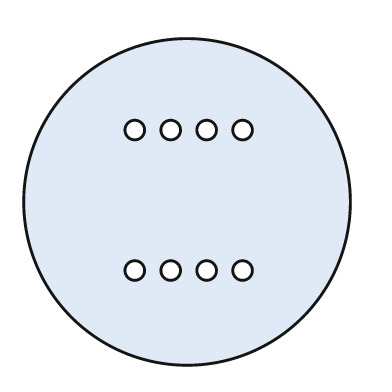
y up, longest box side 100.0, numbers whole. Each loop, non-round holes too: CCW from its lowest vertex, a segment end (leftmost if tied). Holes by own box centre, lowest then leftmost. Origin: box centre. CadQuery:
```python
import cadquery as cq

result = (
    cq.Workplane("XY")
    .moveTo(0.0, 0.0)
    .circle(50.0)
    .moveTo(-16.0, -21.0)
    .circle(3.0)
    .moveTo(-5.0, -21.0)
    .circle(3.0)
    .moveTo(6.0, -21.0)
    .circle(3.0)
    .moveTo(17.0, -21.0)
    .circle(3.0)
    .moveTo(-16.0, 22.0)
    .circle(3.0)
    .moveTo(-5.0, 22.0)
    .circle(3.0)
    .moveTo(6.0, 22.0)
    .circle(3.0)
    .moveTo(17.0, 22.0)
    .circle(3.0)
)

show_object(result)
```